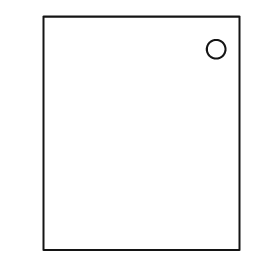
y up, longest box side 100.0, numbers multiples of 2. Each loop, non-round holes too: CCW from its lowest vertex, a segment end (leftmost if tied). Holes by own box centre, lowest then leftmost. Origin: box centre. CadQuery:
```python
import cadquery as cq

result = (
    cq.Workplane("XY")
    .moveTo(-42.0, -50.0)
    .lineTo(42.0, -50.0)
    .lineTo(42.0, 50.0)
    .lineTo(-42.0, 50.0)
    .close()
    .moveTo(32.0, 36.0)
    .circle(4.0)
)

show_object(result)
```